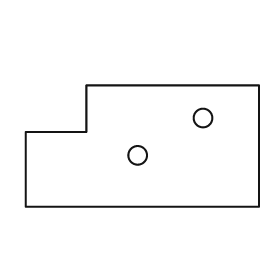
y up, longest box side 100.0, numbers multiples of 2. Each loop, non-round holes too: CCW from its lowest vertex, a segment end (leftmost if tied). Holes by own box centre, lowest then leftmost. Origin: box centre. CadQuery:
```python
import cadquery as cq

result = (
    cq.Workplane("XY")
    .moveTo(-50.0, -26.0)
    .lineTo(50.0, -26.0)
    .lineTo(50.0, 26.0)
    .lineTo(-24.0, 26.0)
    .lineTo(-24.0, 6.0)
    .lineTo(-50.0, 6.0)
    .close()
    .moveTo(-2.0, -4.0)
    .circle(4.0)
    .moveTo(26.0, 12.0)
    .circle(4.0)
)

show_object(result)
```